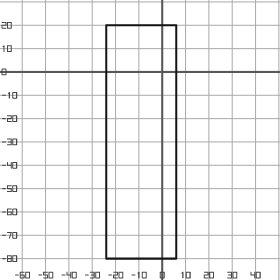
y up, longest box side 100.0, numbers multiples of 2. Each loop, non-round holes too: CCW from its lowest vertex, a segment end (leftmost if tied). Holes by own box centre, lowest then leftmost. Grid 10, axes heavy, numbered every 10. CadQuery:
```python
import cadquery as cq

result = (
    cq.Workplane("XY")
    .moveTo(-24.0, -80.0)
    .lineTo(6.0, -80.0)
    .lineTo(6.0, 20.0)
    .lineTo(-24.0, 20.0)
    .close()
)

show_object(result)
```